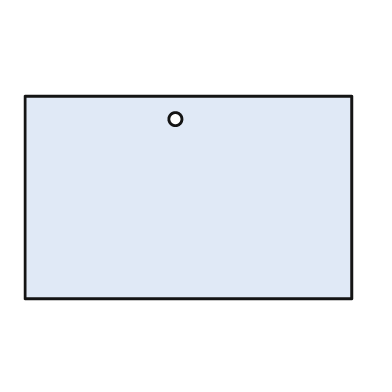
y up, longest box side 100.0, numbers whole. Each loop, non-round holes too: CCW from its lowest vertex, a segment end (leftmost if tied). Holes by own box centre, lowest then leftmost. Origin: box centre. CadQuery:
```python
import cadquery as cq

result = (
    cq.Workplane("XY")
    .moveTo(-50.0, -31.0)
    .lineTo(50.0, -31.0)
    .lineTo(50.0, 31.0)
    .lineTo(-50.0, 31.0)
    .close()
    .moveTo(-4.0, 24.0)
    .circle(2.0)
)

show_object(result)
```